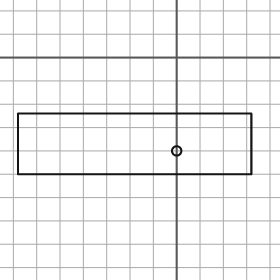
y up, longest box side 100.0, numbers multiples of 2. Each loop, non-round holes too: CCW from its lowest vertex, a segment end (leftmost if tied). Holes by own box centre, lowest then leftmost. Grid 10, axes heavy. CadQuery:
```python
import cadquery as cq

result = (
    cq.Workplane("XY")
    .moveTo(-68.0, -50.0)
    .lineTo(32.0, -50.0)
    .lineTo(32.0, -24.0)
    .lineTo(-68.0, -24.0)
    .close()
    .moveTo(0.0, -40.0)
    .circle(2.0)
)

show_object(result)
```